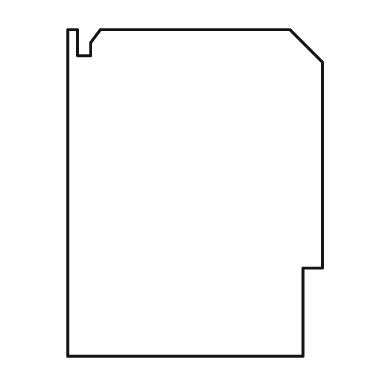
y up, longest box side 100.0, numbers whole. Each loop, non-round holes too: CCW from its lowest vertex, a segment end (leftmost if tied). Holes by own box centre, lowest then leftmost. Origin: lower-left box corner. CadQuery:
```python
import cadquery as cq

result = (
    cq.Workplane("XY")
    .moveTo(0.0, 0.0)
    .lineTo(72.0, 0.0)
    .lineTo(72.0, 27.0)
    .lineTo(78.0, 27.0)
    .lineTo(78.0, 90.0)
    .lineTo(68.0, 100.0)
    .lineTo(10.0, 100.0)
    .lineTo(7.0, 96.0)
    .lineTo(7.0, 92.0)
    .lineTo(3.0, 92.0)
    .lineTo(3.0, 100.0)
    .lineTo(0.0, 100.0)
    .close()
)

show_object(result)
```